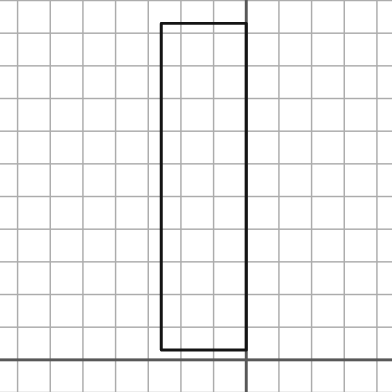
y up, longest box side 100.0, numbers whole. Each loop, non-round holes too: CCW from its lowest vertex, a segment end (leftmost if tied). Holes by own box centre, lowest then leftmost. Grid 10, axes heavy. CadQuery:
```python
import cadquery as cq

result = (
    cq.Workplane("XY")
    .moveTo(-26.0, 3.0)
    .lineTo(0.0, 3.0)
    .lineTo(0.0, 103.0)
    .lineTo(-26.0, 103.0)
    .close()
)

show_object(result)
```